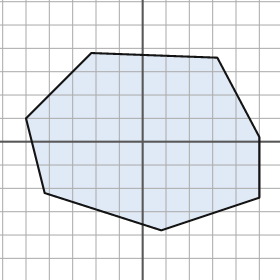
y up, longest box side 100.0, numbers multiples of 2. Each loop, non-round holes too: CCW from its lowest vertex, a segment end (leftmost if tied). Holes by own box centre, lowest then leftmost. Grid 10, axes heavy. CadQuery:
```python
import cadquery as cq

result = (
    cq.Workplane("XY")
    .moveTo(8.0, -38.0)
    .lineTo(50.0, -24.0)
    .lineTo(50.0, 2.0)
    .lineTo(32.0, 36.0)
    .lineTo(-22.0, 38.0)
    .lineTo(-50.0, 10.0)
    .lineTo(-42.0, -22.0)
    .close()
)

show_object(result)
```